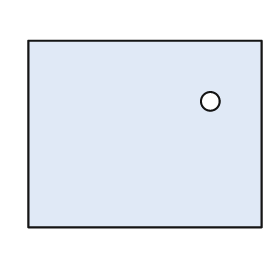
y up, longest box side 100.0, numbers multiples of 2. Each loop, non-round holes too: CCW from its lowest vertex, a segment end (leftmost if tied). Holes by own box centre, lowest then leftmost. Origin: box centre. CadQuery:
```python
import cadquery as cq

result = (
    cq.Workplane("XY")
    .moveTo(-50.0, -40.0)
    .lineTo(50.0, -40.0)
    .lineTo(50.0, 40.0)
    .lineTo(-50.0, 40.0)
    .close()
    .moveTo(28.0, 14.0)
    .circle(4.0)
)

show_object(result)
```